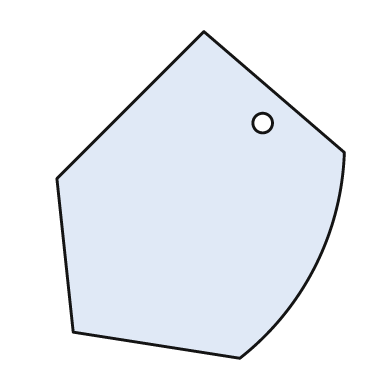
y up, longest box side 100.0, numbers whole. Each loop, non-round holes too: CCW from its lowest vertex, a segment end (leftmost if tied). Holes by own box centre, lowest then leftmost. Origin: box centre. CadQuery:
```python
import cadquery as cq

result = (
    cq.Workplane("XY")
    .moveTo(12.0, -50.0)
    .threePointArc((35.0, -22.0), (44.0, 13.0))
    .lineTo(1.0, 50.0)
    .lineTo(-44.0, 5.0)
    .lineTo(-39.0, -42.0)
    .close()
    .moveTo(19.0, 22.0)
    .circle(3.0)
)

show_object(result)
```